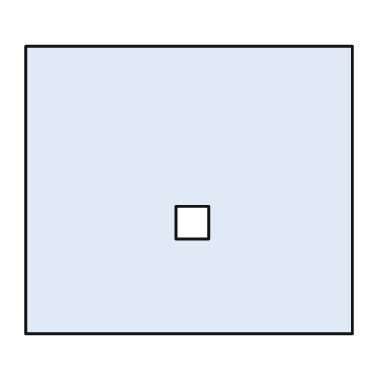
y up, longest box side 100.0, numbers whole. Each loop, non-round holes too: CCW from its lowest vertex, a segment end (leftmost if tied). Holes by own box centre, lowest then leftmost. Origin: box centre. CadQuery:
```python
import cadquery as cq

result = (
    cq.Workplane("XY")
    .moveTo(-50.0, -44.0)
    .lineTo(50.0, -44.0)
    .lineTo(50.0, 44.0)
    .lineTo(-50.0, 44.0)
    .close()
    .moveTo(-4.0, -15.0)
    .lineTo(6.0, -15.0)
    .lineTo(6.0, -5.0)
    .lineTo(-4.0, -5.0)
    .close()
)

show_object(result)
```